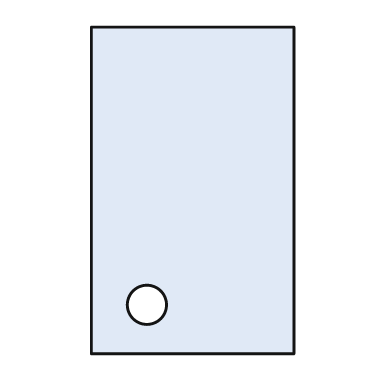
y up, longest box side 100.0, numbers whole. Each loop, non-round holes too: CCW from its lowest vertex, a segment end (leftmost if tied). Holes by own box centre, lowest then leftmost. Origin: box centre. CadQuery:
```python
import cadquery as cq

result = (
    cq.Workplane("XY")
    .moveTo(-31.0, -50.0)
    .lineTo(31.0, -50.0)
    .lineTo(31.0, 50.0)
    .lineTo(-31.0, 50.0)
    .close()
    .moveTo(-14.0, -35.0)
    .circle(6.0)
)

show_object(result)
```